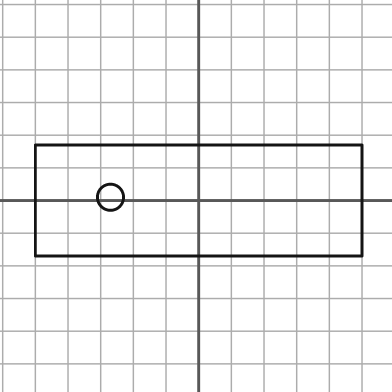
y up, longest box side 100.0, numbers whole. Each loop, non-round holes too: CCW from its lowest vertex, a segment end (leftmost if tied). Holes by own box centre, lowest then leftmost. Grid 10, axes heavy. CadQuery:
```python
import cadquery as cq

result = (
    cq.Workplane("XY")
    .moveTo(-50.0, -17.0)
    .lineTo(50.0, -17.0)
    .lineTo(50.0, 17.0)
    .lineTo(-50.0, 17.0)
    .close()
    .moveTo(-27.0, 1.0)
    .circle(4.0)
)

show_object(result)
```